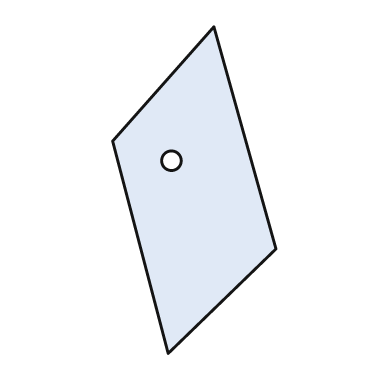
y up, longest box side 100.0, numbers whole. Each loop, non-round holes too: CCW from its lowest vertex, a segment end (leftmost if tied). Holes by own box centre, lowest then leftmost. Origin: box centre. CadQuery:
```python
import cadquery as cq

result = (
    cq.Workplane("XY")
    .moveTo(-8.0, -50.0)
    .lineTo(25.0, -18.0)
    .lineTo(6.0, 50.0)
    .lineTo(-25.0, 15.0)
    .close()
    .moveTo(-7.0, 9.0)
    .circle(3.0)
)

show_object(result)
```